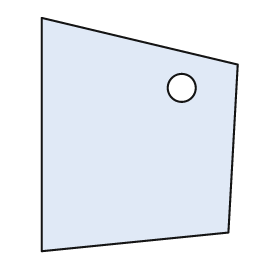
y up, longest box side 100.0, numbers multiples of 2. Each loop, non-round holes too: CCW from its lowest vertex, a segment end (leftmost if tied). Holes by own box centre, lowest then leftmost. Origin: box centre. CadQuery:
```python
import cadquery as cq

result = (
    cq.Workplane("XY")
    .moveTo(-42.0, -50.0)
    .lineTo(38.0, -42.0)
    .lineTo(42.0, 30.0)
    .lineTo(-42.0, 50.0)
    .close()
    .moveTo(18.0, 20.0)
    .circle(6.0)
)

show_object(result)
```